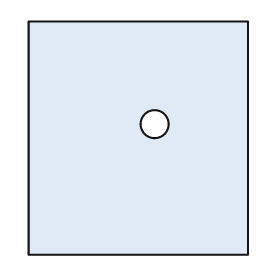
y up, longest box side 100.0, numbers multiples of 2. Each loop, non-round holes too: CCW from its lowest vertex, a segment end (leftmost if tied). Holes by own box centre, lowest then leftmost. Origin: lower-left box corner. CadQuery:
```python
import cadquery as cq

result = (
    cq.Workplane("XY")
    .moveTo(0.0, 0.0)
    .lineTo(94.0, 0.0)
    .lineTo(94.0, 100.0)
    .lineTo(0.0, 100.0)
    .close()
    .moveTo(54.0, 56.0)
    .circle(6.0)
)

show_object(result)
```